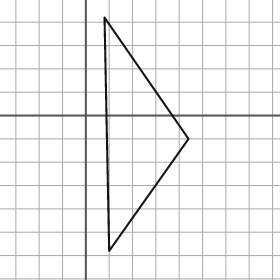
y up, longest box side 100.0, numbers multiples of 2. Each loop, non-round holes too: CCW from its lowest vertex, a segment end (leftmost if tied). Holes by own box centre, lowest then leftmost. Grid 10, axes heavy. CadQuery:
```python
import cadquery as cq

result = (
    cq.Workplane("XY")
    .moveTo(10.0, -58.0)
    .lineTo(44.0, -10.0)
    .lineTo(8.0, 42.0)
    .close()
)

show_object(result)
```